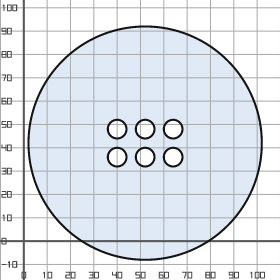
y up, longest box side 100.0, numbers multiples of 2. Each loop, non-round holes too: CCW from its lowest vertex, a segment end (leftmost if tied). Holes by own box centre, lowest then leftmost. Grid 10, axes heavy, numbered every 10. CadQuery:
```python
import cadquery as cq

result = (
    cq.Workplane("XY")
    .moveTo(52.0, 42.0)
    .circle(50.0)
    .moveTo(40.0, 36.0)
    .circle(4.0)
    .moveTo(52.0, 36.0)
    .circle(4.0)
    .moveTo(64.0, 36.0)
    .circle(4.0)
    .moveTo(40.0, 48.0)
    .circle(4.0)
    .moveTo(52.0, 48.0)
    .circle(4.0)
    .moveTo(64.0, 48.0)
    .circle(4.0)
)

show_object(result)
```